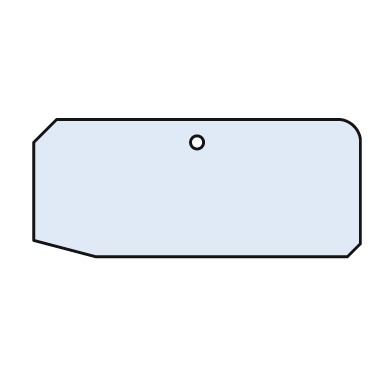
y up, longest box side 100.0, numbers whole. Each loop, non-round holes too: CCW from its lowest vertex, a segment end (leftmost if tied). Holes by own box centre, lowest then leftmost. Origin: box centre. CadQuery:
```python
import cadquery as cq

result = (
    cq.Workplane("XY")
    .moveTo(-31.0, -21.0)
    .lineTo(46.0, -21.0)
    .lineTo(50.0, -17.0)
    .lineTo(50.0, 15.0)
    .threePointArc((48.0, 19.0), (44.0, 21.0))
    .lineTo(-43.0, 21.0)
    .lineTo(-50.0, 14.0)
    .lineTo(-50.0, -16.0)
    .close()
    .moveTo(0.0, 14.0)
    .circle(2.0)
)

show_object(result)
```